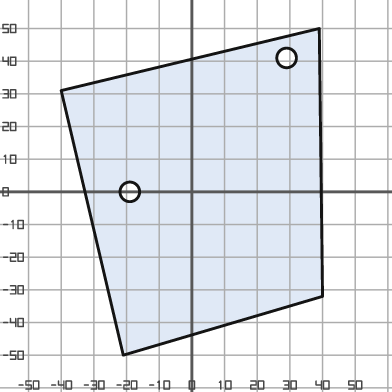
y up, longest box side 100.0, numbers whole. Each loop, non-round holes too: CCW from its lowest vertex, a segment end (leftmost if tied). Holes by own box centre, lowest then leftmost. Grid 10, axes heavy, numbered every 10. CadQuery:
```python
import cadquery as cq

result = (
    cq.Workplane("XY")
    .moveTo(-21.0, -50.0)
    .lineTo(40.0, -32.0)
    .lineTo(39.0, 50.0)
    .lineTo(-40.0, 31.0)
    .close()
    .moveTo(-19.0, 0.0)
    .circle(3.0)
    .moveTo(29.0, 41.0)
    .circle(3.0)
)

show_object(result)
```